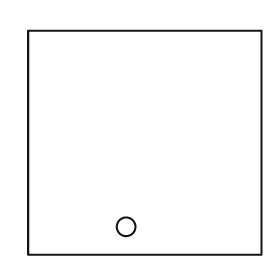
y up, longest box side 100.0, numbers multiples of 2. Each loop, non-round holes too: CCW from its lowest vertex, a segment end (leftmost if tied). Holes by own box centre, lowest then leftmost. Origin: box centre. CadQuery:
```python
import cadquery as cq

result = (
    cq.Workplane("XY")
    .moveTo(-50.0, -48.0)
    .lineTo(50.0, -48.0)
    .lineTo(50.0, 48.0)
    .lineTo(-50.0, 48.0)
    .close()
    .moveTo(-8.0, -36.0)
    .circle(4.0)
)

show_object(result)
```